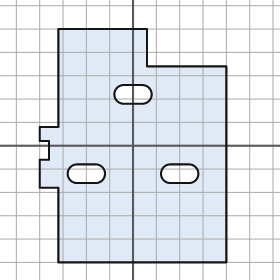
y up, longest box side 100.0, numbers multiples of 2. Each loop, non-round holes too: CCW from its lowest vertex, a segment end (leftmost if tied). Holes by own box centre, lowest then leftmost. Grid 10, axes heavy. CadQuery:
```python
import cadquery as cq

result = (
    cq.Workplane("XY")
    .moveTo(-32.0, -50.0)
    .lineTo(40.0, -50.0)
    .lineTo(40.0, 34.0)
    .lineTo(6.0, 34.0)
    .lineTo(6.0, 50.0)
    .lineTo(-32.0, 50.0)
    .lineTo(-32.0, 8.0)
    .lineTo(-40.0, 8.0)
    .lineTo(-40.0, 2.0)
    .lineTo(-36.0, 2.0)
    .lineTo(-36.0, -6.0)
    .lineTo(-40.0, -6.0)
    .lineTo(-40.0, -18.0)
    .lineTo(-32.0, -18.0)
    .close()
    .moveTo(-24.0, -16.0)
    .lineTo(-16.0, -16.0)
    .threePointArc((-12.0, -12.0), (-16.0, -8.0))
    .lineTo(-24.0, -8.0)
    .threePointArc((-28.0, -12.0), (-24.0, -16.0))
    .close()
    .moveTo(16.0, -16.0)
    .lineTo(24.0, -16.0)
    .threePointArc((28.0, -12.0), (24.0, -8.0))
    .lineTo(16.0, -8.0)
    .threePointArc((12.0, -12.0), (16.0, -16.0))
    .close()
    .moveTo(-4.0, 18.0)
    .lineTo(4.0, 18.0)
    .threePointArc((8.0, 22.0), (4.0, 26.0))
    .lineTo(-4.0, 26.0)
    .threePointArc((-8.0, 22.0), (-4.0, 18.0))
    .close()
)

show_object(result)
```